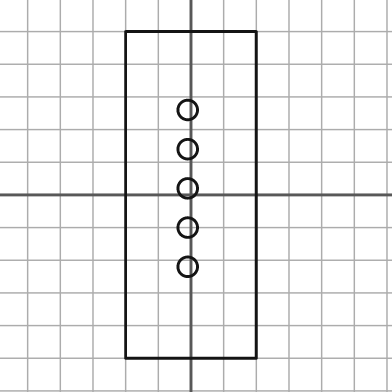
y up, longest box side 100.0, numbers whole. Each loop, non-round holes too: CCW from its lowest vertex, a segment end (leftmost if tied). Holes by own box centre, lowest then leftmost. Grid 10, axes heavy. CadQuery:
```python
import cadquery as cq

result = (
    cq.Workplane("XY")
    .moveTo(-20.0, -50.0)
    .lineTo(20.0, -50.0)
    .lineTo(20.0, 50.0)
    .lineTo(-20.0, 50.0)
    .close()
    .moveTo(-1.0, -22.0)
    .circle(3.0)
    .moveTo(-1.0, -10.0)
    .circle(3.0)
    .moveTo(-1.0, 2.0)
    .circle(3.0)
    .moveTo(-1.0, 14.0)
    .circle(3.0)
    .moveTo(-1.0, 26.0)
    .circle(3.0)
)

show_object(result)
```